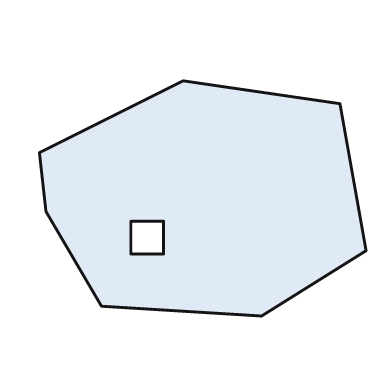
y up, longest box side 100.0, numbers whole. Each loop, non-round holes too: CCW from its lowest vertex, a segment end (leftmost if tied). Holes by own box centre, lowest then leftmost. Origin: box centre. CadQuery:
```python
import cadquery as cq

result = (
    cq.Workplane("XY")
    .moveTo(18.0, -36.0)
    .lineTo(50.0, -16.0)
    .lineTo(42.0, 29.0)
    .lineTo(-6.0, 36.0)
    .lineTo(-50.0, 14.0)
    .lineTo(-48.0, -4.0)
    .lineTo(-31.0, -33.0)
    .close()
    .moveTo(-22.0, -17.0)
    .lineTo(-12.0, -17.0)
    .lineTo(-12.0, -7.0)
    .lineTo(-22.0, -7.0)
    .close()
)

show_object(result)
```